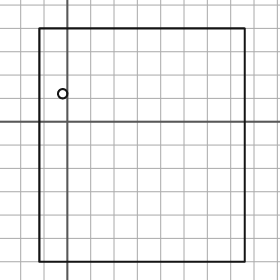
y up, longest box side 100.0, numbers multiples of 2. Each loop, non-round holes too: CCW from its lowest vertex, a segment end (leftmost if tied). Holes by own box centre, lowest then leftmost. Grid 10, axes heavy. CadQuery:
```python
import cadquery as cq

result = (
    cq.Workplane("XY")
    .moveTo(-12.0, -60.0)
    .lineTo(76.0, -60.0)
    .lineTo(76.0, 40.0)
    .lineTo(-12.0, 40.0)
    .close()
    .moveTo(-2.0, 12.0)
    .circle(2.0)
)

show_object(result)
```